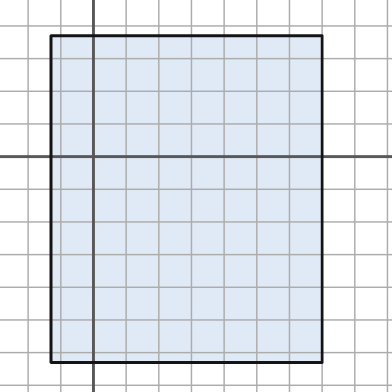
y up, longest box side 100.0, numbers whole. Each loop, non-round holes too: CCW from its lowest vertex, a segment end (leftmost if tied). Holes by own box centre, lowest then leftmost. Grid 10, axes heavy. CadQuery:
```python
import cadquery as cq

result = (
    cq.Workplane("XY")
    .moveTo(-13.0, -63.0)
    .lineTo(70.0, -63.0)
    .lineTo(70.0, 37.0)
    .lineTo(-13.0, 37.0)
    .close()
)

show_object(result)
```